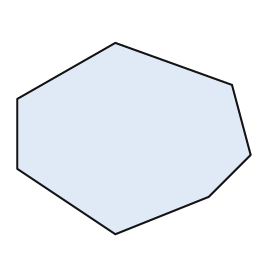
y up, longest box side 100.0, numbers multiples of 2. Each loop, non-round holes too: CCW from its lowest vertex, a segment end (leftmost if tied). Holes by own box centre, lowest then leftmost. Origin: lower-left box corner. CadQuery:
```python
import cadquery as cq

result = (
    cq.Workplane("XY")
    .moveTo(42.0, 0.0)
    .lineTo(82.0, 16.0)
    .lineTo(100.0, 34.0)
    .lineTo(92.0, 64.0)
    .lineTo(42.0, 82.0)
    .lineTo(0.0, 58.0)
    .lineTo(0.0, 28.0)
    .close()
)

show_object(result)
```